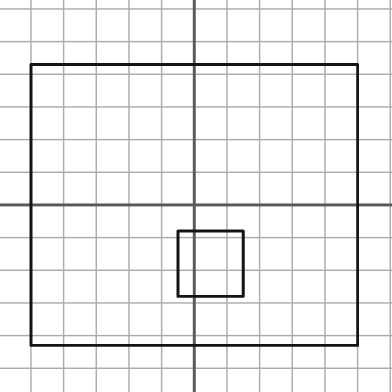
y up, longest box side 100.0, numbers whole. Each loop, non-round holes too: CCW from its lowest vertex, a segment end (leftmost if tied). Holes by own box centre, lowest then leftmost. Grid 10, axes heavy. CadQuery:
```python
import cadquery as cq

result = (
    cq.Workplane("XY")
    .moveTo(-50.0, -43.0)
    .lineTo(50.0, -43.0)
    .lineTo(50.0, 43.0)
    .lineTo(-50.0, 43.0)
    .close()
    .moveTo(-5.0, -28.0)
    .lineTo(15.0, -28.0)
    .lineTo(15.0, -8.0)
    .lineTo(-5.0, -8.0)
    .close()
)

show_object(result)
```